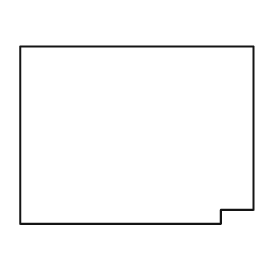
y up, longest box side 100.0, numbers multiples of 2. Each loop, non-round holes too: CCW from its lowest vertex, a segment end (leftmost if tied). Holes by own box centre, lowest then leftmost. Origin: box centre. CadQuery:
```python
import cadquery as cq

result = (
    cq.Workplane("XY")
    .moveTo(-50.0, -38.0)
    .lineTo(36.0, -38.0)
    .lineTo(36.0, -32.0)
    .lineTo(50.0, -32.0)
    .lineTo(50.0, 38.0)
    .lineTo(-50.0, 38.0)
    .close()
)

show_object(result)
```